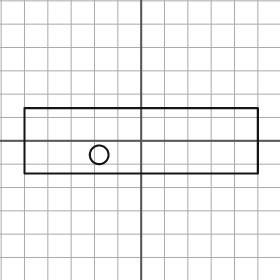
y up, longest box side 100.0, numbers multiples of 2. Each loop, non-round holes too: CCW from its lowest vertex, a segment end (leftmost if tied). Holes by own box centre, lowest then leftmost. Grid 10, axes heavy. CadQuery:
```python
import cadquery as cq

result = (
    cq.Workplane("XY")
    .moveTo(-50.0, -14.0)
    .lineTo(50.0, -14.0)
    .lineTo(50.0, 14.0)
    .lineTo(-50.0, 14.0)
    .close()
    .moveTo(-18.0, -6.0)
    .circle(4.0)
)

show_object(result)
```